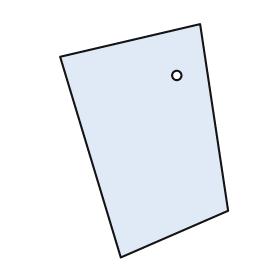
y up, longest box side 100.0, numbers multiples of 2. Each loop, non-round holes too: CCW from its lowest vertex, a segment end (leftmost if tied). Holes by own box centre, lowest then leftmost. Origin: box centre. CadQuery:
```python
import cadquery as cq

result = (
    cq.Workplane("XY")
    .moveTo(-10.0, -50.0)
    .lineTo(36.0, -30.0)
    .lineTo(24.0, 50.0)
    .lineTo(-36.0, 36.0)
    .close()
    .moveTo(14.0, 28.0)
    .circle(2.0)
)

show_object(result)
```